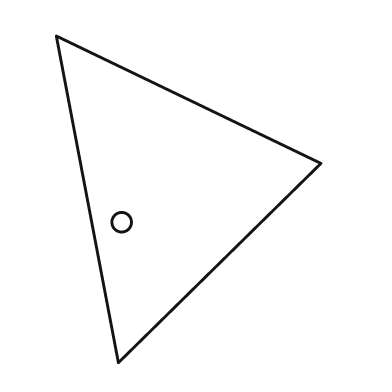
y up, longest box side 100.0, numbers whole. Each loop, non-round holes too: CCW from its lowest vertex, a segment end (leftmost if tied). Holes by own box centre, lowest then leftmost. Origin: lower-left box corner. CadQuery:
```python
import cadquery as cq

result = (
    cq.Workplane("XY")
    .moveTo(19.0, 0.0)
    .lineTo(81.0, 61.0)
    .lineTo(0.0, 100.0)
    .close()
    .moveTo(20.0, 43.0)
    .circle(3.0)
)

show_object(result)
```